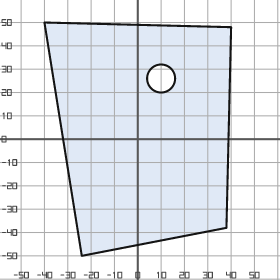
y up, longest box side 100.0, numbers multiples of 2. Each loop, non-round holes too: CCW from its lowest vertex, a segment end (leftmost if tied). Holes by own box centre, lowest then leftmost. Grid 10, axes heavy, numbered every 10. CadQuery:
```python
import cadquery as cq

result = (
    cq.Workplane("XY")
    .moveTo(-24.0, -50.0)
    .lineTo(38.0, -38.0)
    .lineTo(40.0, 48.0)
    .lineTo(-40.0, 50.0)
    .close()
    .moveTo(10.0, 26.0)
    .circle(6.0)
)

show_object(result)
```